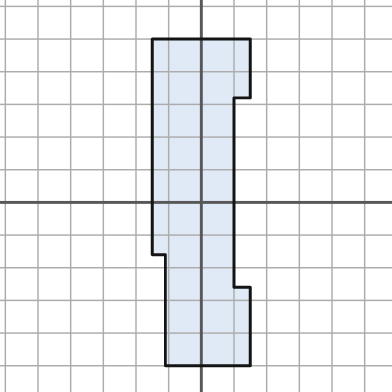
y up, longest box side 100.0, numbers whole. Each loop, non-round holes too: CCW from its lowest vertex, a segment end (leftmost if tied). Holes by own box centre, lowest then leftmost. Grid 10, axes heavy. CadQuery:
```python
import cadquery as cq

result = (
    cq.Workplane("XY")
    .moveTo(-11.0, -50.0)
    .lineTo(15.0, -50.0)
    .lineTo(15.0, -26.0)
    .lineTo(10.0, -26.0)
    .lineTo(10.0, 32.0)
    .lineTo(15.0, 32.0)
    .lineTo(15.0, 50.0)
    .lineTo(-15.0, 50.0)
    .lineTo(-15.0, -16.0)
    .lineTo(-11.0, -16.0)
    .close()
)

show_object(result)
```